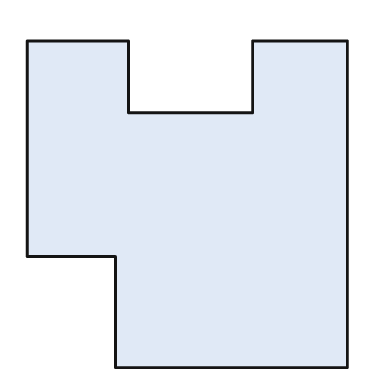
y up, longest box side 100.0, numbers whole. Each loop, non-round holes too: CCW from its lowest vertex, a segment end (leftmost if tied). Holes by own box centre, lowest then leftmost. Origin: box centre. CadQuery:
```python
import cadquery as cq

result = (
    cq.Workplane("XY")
    .moveTo(-22.0, -50.0)
    .lineTo(49.0, -50.0)
    .lineTo(49.0, 50.0)
    .lineTo(20.0, 50.0)
    .lineTo(20.0, 28.0)
    .lineTo(-18.0, 28.0)
    .lineTo(-18.0, 50.0)
    .lineTo(-49.0, 50.0)
    .lineTo(-49.0, -16.0)
    .lineTo(-22.0, -16.0)
    .close()
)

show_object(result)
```